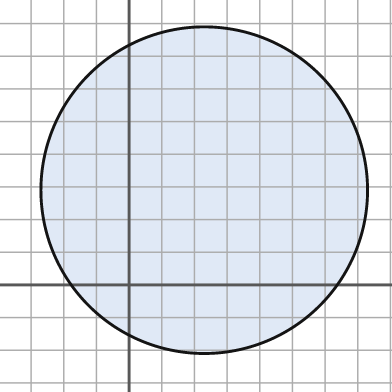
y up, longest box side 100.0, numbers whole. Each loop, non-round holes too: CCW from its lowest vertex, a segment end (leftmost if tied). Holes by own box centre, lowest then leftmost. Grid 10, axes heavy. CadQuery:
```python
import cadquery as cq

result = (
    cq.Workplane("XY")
    .moveTo(23.0, 29.0)
    .circle(50.0)
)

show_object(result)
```